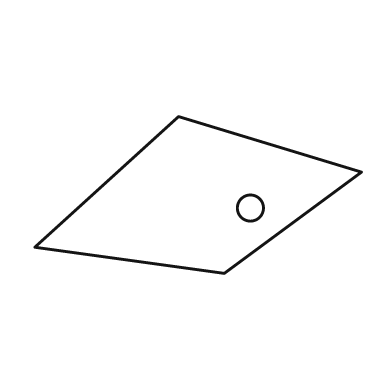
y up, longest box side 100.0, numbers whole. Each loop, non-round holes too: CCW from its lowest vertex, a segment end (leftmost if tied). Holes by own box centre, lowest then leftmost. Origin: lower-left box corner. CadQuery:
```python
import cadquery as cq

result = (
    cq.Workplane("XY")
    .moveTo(58.0, 0.0)
    .lineTo(100.0, 31.0)
    .lineTo(44.0, 48.0)
    .lineTo(0.0, 8.0)
    .close()
    .moveTo(66.0, 20.0)
    .circle(4.0)
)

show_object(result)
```